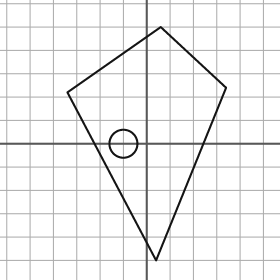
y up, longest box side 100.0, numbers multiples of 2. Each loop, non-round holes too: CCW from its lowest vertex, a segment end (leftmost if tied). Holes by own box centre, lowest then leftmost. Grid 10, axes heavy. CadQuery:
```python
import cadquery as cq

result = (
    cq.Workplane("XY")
    .moveTo(4.0, -50.0)
    .lineTo(34.0, 24.0)
    .lineTo(6.0, 50.0)
    .lineTo(-34.0, 22.0)
    .close()
    .moveTo(-10.0, 0.0)
    .circle(6.0)
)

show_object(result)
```